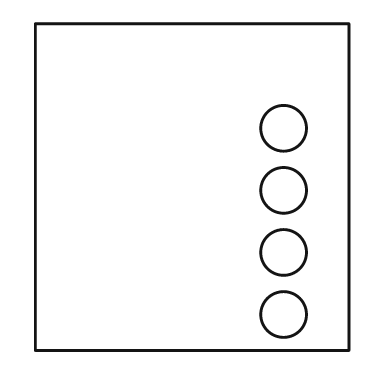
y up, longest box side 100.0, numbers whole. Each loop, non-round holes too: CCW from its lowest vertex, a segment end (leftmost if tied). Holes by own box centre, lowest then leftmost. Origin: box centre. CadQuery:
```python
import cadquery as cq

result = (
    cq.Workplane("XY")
    .moveTo(-48.0, -50.0)
    .lineTo(48.0, -50.0)
    .lineTo(48.0, 50.0)
    .lineTo(-48.0, 50.0)
    .close()
    .moveTo(28.0, -39.0)
    .circle(7.0)
    .moveTo(28.0, -20.0)
    .circle(7.0)
    .moveTo(28.0, -1.0)
    .circle(7.0)
    .moveTo(28.0, 18.0)
    .circle(7.0)
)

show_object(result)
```